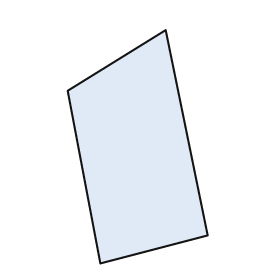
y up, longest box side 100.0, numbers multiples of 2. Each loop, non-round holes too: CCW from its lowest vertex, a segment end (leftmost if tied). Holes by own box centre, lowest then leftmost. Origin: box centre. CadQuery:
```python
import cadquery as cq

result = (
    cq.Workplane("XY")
    .moveTo(-16.0, -50.0)
    .lineTo(30.0, -38.0)
    .lineTo(12.0, 50.0)
    .lineTo(-30.0, 24.0)
    .close()
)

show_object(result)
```